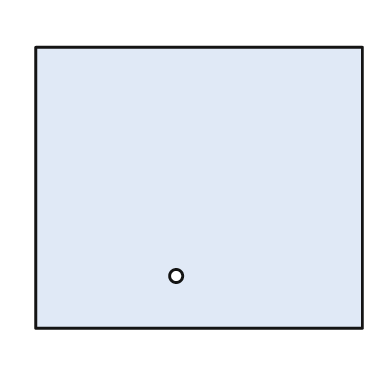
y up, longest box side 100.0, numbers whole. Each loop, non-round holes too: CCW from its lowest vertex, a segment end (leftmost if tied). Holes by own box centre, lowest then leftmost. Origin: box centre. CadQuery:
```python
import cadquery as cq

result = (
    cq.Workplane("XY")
    .moveTo(-50.0, -43.0)
    .lineTo(50.0, -43.0)
    .lineTo(50.0, 43.0)
    .lineTo(-50.0, 43.0)
    .close()
    .moveTo(-7.0, -27.0)
    .circle(2.0)
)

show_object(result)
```